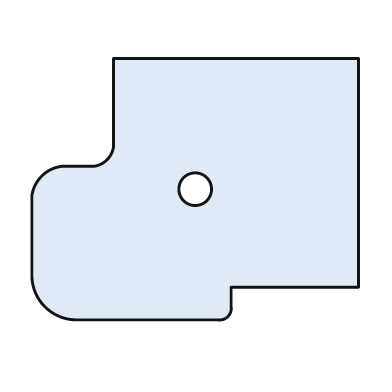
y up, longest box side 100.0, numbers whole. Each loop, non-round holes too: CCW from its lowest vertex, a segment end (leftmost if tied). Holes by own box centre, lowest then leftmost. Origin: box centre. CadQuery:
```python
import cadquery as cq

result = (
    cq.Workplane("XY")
    .moveTo(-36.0, -40.0)
    .lineTo(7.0, -40.0)
    .threePointArc((10.0, -39.0), (11.0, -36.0))
    .lineTo(11.0, -30.0)
    .lineTo(50.0, -30.0)
    .lineTo(50.0, 40.0)
    .lineTo(-25.0, 40.0)
    .lineTo(-25.0, 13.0)
    .threePointArc((-27.0, 9.0), (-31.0, 7.0))
    .lineTo(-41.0, 7.0)
    .threePointArc((-47.0, 4.0), (-50.0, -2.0))
    .lineTo(-50.0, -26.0)
    .threePointArc((-46.0, -36.0), (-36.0, -40.0))
    .close()
    .moveTo(0.0, 0.0)
    .circle(5.0)
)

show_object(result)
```